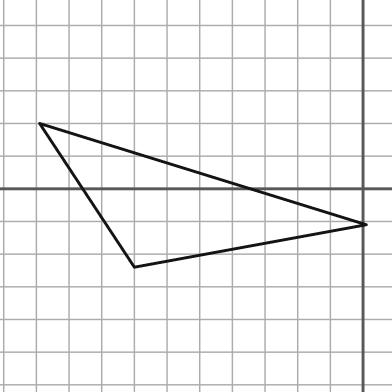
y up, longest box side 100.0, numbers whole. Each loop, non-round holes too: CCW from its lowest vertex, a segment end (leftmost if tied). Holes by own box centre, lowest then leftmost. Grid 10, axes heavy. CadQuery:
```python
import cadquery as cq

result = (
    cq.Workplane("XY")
    .moveTo(-70.0, -24.0)
    .lineTo(1.0, -11.0)
    .lineTo(-99.0, 20.0)
    .close()
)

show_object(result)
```